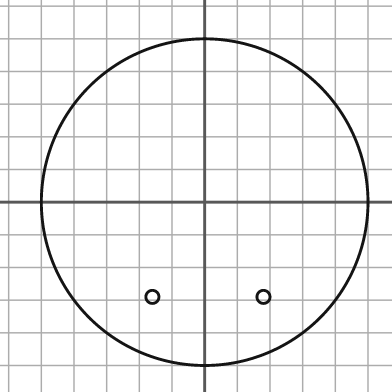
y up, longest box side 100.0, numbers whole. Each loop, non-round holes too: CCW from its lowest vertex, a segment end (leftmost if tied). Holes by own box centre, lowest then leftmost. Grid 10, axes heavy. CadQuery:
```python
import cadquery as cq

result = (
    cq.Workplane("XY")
    .moveTo(0.0, 0.0)
    .circle(50.0)
    .moveTo(-16.0, -29.0)
    .circle(2.0)
    .moveTo(18.0, -29.0)
    .circle(2.0)
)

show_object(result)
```